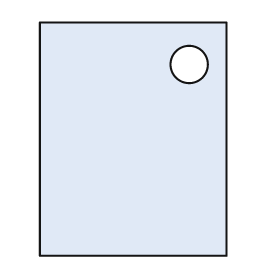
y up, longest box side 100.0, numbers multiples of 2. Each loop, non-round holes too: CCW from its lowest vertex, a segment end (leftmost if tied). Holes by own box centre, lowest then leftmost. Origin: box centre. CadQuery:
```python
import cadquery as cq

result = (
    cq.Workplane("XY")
    .moveTo(-40.0, -50.0)
    .lineTo(40.0, -50.0)
    .lineTo(40.0, 50.0)
    .lineTo(-40.0, 50.0)
    .close()
    .moveTo(24.0, 32.0)
    .circle(8.0)
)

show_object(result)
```